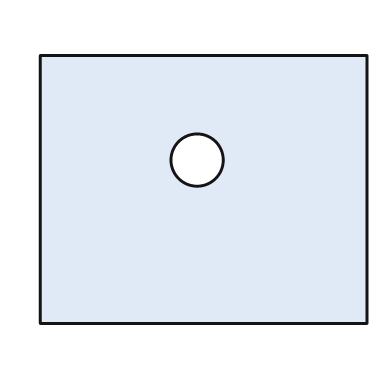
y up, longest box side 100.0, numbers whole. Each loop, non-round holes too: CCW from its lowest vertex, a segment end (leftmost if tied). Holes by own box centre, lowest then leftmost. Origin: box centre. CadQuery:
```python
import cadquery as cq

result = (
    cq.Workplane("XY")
    .moveTo(-50.0, -41.0)
    .lineTo(50.0, -41.0)
    .lineTo(50.0, 41.0)
    .lineTo(-50.0, 41.0)
    .close()
    .moveTo(-2.0, 9.0)
    .circle(8.0)
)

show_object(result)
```